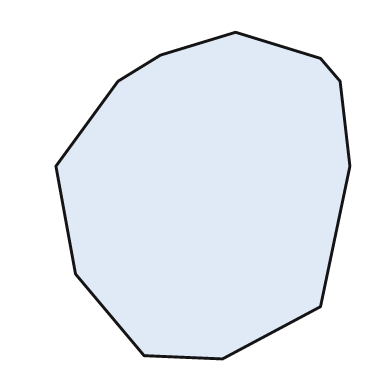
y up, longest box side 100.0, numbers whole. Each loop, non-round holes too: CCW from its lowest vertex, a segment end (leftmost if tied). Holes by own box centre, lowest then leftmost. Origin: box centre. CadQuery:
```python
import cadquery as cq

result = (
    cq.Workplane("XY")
    .moveTo(6.0, -50.0)
    .lineTo(36.0, -34.0)
    .lineTo(45.0, 9.0)
    .lineTo(42.0, 35.0)
    .lineTo(36.0, 42.0)
    .lineTo(10.0, 50.0)
    .lineTo(-13.0, 43.0)
    .lineTo(-26.0, 35.0)
    .lineTo(-45.0, 9.0)
    .lineTo(-39.0, -24.0)
    .lineTo(-18.0, -49.0)
    .close()
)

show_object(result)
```